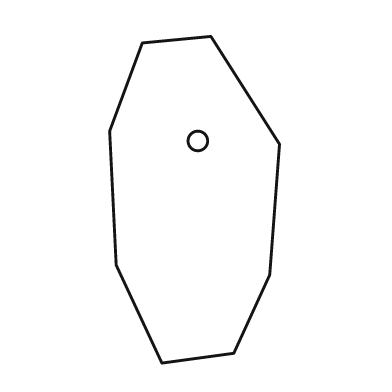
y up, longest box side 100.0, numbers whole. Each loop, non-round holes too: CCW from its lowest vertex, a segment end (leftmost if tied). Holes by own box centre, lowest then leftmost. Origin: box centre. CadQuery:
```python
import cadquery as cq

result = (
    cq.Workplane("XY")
    .moveTo(-10.0, -50.0)
    .lineTo(12.0, -47.0)
    .lineTo(23.0, -23.0)
    .lineTo(26.0, 17.0)
    .lineTo(5.0, 50.0)
    .lineTo(-16.0, 48.0)
    .lineTo(-26.0, 21.0)
    .lineTo(-24.0, -20.0)
    .close()
    .moveTo(1.0, 18.0)
    .circle(3.0)
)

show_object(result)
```